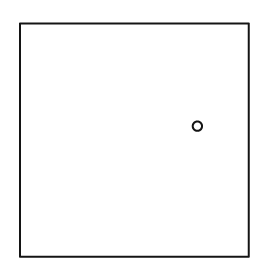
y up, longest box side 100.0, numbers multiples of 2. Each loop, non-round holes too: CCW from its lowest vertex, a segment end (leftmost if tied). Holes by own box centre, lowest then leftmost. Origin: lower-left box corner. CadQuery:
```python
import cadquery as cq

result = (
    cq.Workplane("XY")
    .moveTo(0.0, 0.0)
    .lineTo(98.0, 0.0)
    .lineTo(98.0, 100.0)
    .lineTo(0.0, 100.0)
    .close()
    .moveTo(76.0, 56.0)
    .circle(2.0)
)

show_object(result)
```